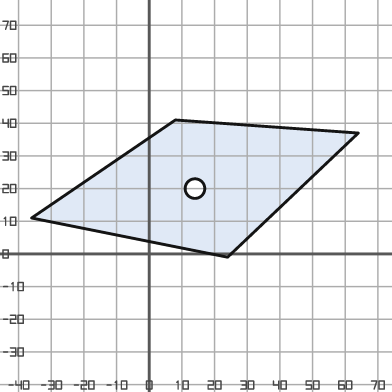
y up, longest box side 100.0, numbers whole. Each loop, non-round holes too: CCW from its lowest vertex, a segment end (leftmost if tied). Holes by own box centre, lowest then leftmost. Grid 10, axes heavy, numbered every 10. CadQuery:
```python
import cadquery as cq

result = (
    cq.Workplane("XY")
    .moveTo(24.0, -1.0)
    .lineTo(64.0, 37.0)
    .lineTo(8.0, 41.0)
    .lineTo(-36.0, 11.0)
    .close()
    .moveTo(14.0, 20.0)
    .circle(3.0)
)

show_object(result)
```